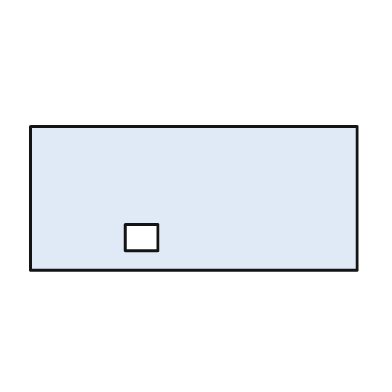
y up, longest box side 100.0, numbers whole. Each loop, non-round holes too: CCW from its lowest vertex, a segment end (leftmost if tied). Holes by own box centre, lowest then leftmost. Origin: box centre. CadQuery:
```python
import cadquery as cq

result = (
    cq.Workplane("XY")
    .moveTo(-50.0, -22.0)
    .lineTo(50.0, -22.0)
    .lineTo(50.0, 22.0)
    .lineTo(-50.0, 22.0)
    .close()
    .moveTo(-21.0, -16.0)
    .lineTo(-11.0, -16.0)
    .lineTo(-11.0, -8.0)
    .lineTo(-21.0, -8.0)
    .close()
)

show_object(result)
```